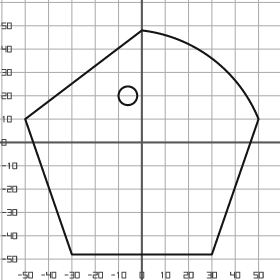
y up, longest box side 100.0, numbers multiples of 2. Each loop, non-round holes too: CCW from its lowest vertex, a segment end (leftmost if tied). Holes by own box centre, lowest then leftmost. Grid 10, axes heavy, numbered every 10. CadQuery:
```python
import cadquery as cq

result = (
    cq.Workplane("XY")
    .moveTo(-30.0, -48.0)
    .lineTo(30.0, -48.0)
    .lineTo(50.0, 10.0)
    .threePointArc((30.0, 36.0), (0.0, 48.0))
    .lineTo(-50.0, 10.0)
    .close()
    .moveTo(-6.0, 20.0)
    .circle(4.0)
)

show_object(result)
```